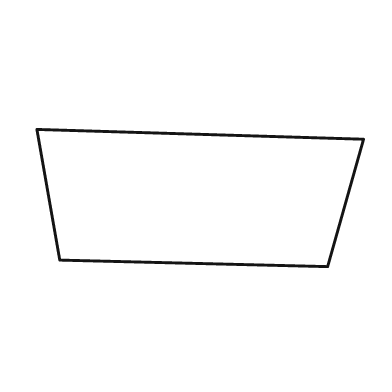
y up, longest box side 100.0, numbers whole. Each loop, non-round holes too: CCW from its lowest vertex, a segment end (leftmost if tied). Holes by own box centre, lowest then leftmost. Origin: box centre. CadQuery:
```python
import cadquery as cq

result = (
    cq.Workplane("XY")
    .moveTo(39.0, -21.0)
    .lineTo(50.0, 18.0)
    .lineTo(-50.0, 21.0)
    .lineTo(-43.0, -19.0)
    .close()
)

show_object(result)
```